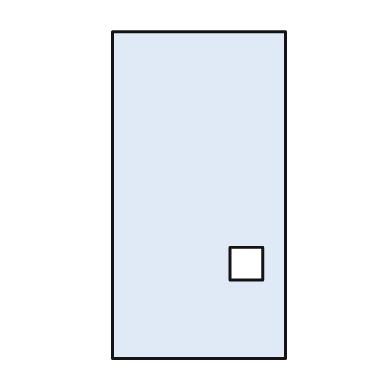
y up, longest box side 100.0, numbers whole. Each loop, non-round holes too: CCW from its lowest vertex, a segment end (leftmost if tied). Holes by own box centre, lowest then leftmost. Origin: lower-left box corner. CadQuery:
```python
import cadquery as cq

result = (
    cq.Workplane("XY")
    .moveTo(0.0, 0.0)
    .lineTo(53.0, 0.0)
    .lineTo(53.0, 100.0)
    .lineTo(0.0, 100.0)
    .close()
    .moveTo(36.0, 24.0)
    .lineTo(46.0, 24.0)
    .lineTo(46.0, 34.0)
    .lineTo(36.0, 34.0)
    .close()
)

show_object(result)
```